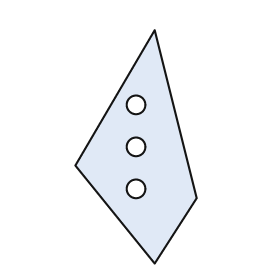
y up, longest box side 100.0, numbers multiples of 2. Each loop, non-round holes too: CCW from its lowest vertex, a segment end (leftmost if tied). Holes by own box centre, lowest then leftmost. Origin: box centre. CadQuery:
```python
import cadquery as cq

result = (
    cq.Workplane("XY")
    .moveTo(8.0, -50.0)
    .lineTo(26.0, -22.0)
    .lineTo(8.0, 50.0)
    .lineTo(-26.0, -8.0)
    .close()
    .moveTo(0.0, -18.0)
    .circle(4.0)
    .moveTo(0.0, 0.0)
    .circle(4.0)
    .moveTo(0.0, 18.0)
    .circle(4.0)
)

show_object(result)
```